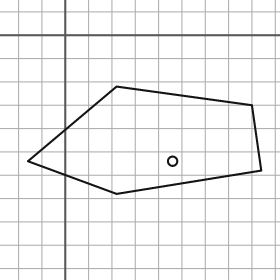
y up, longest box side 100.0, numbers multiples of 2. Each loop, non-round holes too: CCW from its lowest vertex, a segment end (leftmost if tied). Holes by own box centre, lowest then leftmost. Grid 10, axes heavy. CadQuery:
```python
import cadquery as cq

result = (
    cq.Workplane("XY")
    .moveTo(22.0, -68.0)
    .lineTo(84.0, -58.0)
    .lineTo(80.0, -30.0)
    .lineTo(22.0, -22.0)
    .lineTo(-16.0, -54.0)
    .close()
    .moveTo(46.0, -54.0)
    .circle(2.0)
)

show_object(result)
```